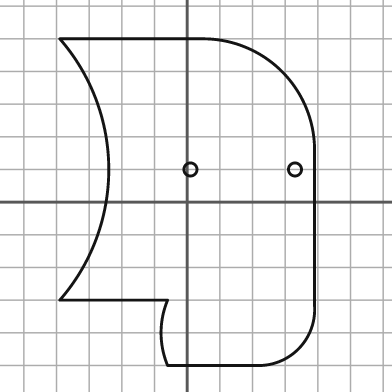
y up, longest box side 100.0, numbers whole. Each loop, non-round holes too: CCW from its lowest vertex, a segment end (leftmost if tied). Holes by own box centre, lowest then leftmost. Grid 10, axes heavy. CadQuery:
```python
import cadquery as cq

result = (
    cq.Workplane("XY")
    .moveTo(-6.0, -50.0)
    .lineTo(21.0, -50.0)
    .threePointArc((34.0, -45.0), (39.0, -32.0))
    .lineTo(39.0, 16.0)
    .threePointArc((29.0, 40.0), (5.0, 50.0))
    .lineTo(-39.0, 50.0)
    .threePointArc((-24.0, 10.0), (-39.0, -30.0))
    .lineTo(-6.0, -30.0)
    .threePointArc((-8.0, -40.0), (-6.0, -50.0))
    .close()
    .moveTo(1.0, 10.0)
    .circle(2.0)
    .moveTo(33.0, 10.0)
    .circle(2.0)
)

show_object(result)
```